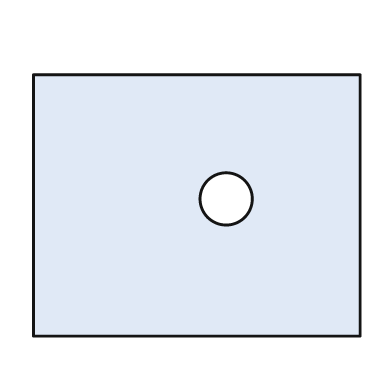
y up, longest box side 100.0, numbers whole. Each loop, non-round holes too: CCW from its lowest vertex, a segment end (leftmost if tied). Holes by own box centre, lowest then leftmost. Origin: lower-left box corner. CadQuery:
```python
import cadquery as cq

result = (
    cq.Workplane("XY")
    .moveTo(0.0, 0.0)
    .lineTo(100.0, 0.0)
    .lineTo(100.0, 80.0)
    .lineTo(0.0, 80.0)
    .close()
    .moveTo(59.0, 42.0)
    .circle(8.0)
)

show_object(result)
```